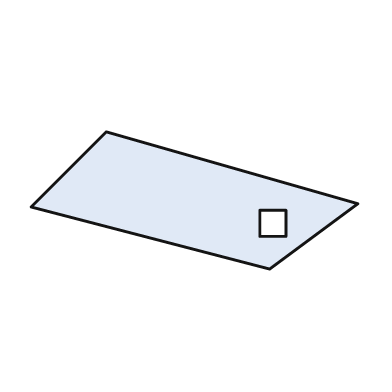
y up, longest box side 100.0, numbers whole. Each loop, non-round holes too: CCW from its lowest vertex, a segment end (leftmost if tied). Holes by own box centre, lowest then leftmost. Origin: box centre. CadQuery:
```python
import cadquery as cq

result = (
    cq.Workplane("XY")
    .moveTo(23.0, -21.0)
    .lineTo(50.0, -1.0)
    .lineTo(-27.0, 21.0)
    .lineTo(-50.0, -2.0)
    .close()
    .moveTo(20.0, -11.0)
    .lineTo(28.0, -11.0)
    .lineTo(28.0, -3.0)
    .lineTo(20.0, -3.0)
    .close()
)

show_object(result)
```